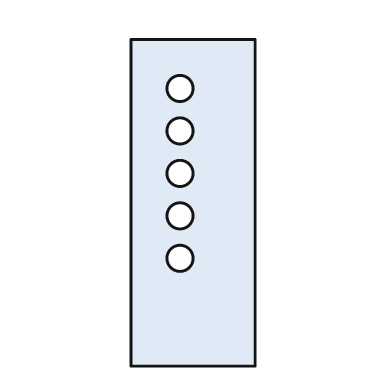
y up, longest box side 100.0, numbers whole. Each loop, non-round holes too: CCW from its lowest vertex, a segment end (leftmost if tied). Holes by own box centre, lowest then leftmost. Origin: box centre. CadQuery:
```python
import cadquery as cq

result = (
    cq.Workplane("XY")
    .moveTo(-19.0, -50.0)
    .lineTo(19.0, -50.0)
    .lineTo(19.0, 50.0)
    .lineTo(-19.0, 50.0)
    .close()
    .moveTo(-4.0, -17.0)
    .circle(4.0)
    .moveTo(-4.0, -4.0)
    .circle(4.0)
    .moveTo(-4.0, 9.0)
    .circle(4.0)
    .moveTo(-4.0, 22.0)
    .circle(4.0)
    .moveTo(-4.0, 35.0)
    .circle(4.0)
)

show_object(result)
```